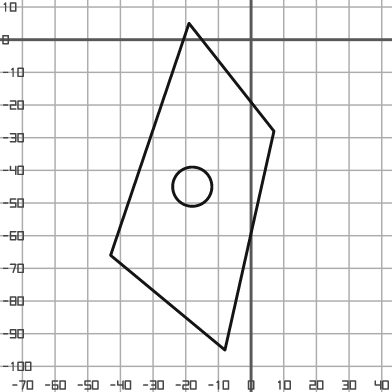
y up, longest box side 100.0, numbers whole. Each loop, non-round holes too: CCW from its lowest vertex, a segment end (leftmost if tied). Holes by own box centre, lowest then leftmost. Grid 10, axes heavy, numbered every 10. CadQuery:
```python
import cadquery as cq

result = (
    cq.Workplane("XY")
    .moveTo(-8.0, -95.0)
    .lineTo(7.0, -28.0)
    .lineTo(-19.0, 5.0)
    .lineTo(-43.0, -66.0)
    .close()
    .moveTo(-18.0, -45.0)
    .circle(6.0)
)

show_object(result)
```